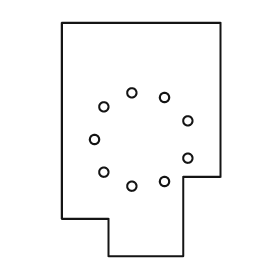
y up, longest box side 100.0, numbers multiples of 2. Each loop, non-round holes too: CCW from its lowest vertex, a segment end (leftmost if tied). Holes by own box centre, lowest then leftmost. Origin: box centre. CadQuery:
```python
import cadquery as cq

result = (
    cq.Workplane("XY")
    .moveTo(-14.0, -50.0)
    .lineTo(18.0, -50.0)
    .lineTo(18.0, -16.0)
    .lineTo(34.0, -16.0)
    .lineTo(34.0, 50.0)
    .lineTo(-34.0, 50.0)
    .lineTo(-34.0, -34.0)
    .lineTo(-14.0, -34.0)
    .close()
    .moveTo(-4.0, -20.0)
    .circle(2.0)
    .moveTo(10.0, -18.0)
    .circle(2.0)
    .moveTo(-16.0, -14.0)
    .circle(2.0)
    .moveTo(20.0, -8.0)
    .circle(2.0)
    .moveTo(-20.0, 0.0)
    .circle(2.0)
    .moveTo(20.0, 8.0)
    .circle(2.0)
    .moveTo(-16.0, 14.0)
    .circle(2.0)
    .moveTo(10.0, 18.0)
    .circle(2.0)
    .moveTo(-4.0, 20.0)
    .circle(2.0)
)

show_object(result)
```